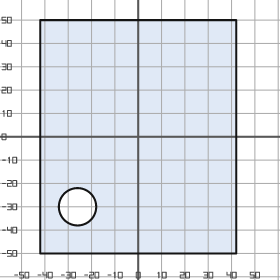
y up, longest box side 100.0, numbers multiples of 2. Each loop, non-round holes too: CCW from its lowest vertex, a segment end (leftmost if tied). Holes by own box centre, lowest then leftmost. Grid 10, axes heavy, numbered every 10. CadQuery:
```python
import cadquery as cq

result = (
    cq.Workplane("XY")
    .moveTo(-42.0, -50.0)
    .lineTo(42.0, -50.0)
    .lineTo(42.0, 50.0)
    .lineTo(-42.0, 50.0)
    .close()
    .moveTo(-26.0, -30.0)
    .circle(8.0)
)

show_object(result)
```